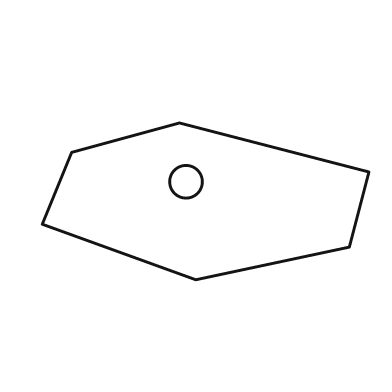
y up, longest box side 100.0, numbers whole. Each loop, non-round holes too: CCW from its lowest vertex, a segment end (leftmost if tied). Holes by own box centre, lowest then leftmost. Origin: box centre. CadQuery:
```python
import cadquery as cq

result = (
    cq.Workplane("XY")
    .moveTo(-3.0, -24.0)
    .lineTo(44.0, -14.0)
    .lineTo(50.0, 9.0)
    .lineTo(-8.0, 24.0)
    .lineTo(-41.0, 15.0)
    .lineTo(-50.0, -7.0)
    .close()
    .moveTo(-6.0, 6.0)
    .circle(5.0)
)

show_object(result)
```